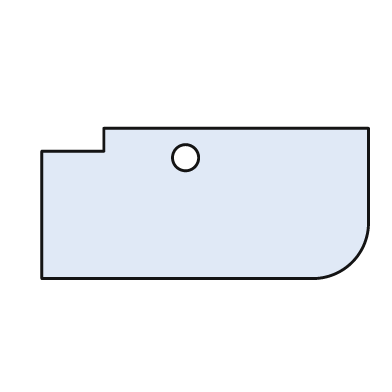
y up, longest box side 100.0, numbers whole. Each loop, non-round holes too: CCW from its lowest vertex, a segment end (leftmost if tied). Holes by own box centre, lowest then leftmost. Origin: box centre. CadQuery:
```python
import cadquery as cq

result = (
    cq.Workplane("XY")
    .moveTo(-50.0, -23.0)
    .lineTo(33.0, -23.0)
    .threePointArc((45.0, -18.0), (50.0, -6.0))
    .lineTo(50.0, 23.0)
    .lineTo(-31.0, 23.0)
    .lineTo(-31.0, 16.0)
    .lineTo(-50.0, 16.0)
    .close()
    .moveTo(-6.0, 14.0)
    .circle(4.0)
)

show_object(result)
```